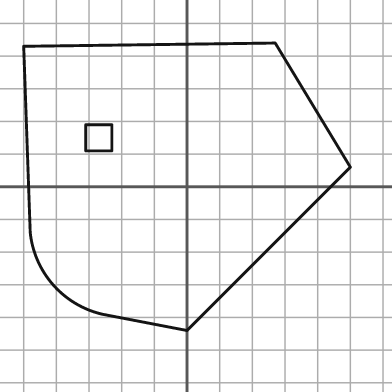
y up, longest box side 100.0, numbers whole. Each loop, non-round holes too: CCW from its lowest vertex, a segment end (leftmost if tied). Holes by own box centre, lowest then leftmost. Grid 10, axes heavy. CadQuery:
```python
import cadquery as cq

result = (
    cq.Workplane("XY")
    .moveTo(0.0, -44.0)
    .lineTo(50.0, 6.0)
    .lineTo(27.0, 44.0)
    .lineTo(-50.0, 43.0)
    .lineTo(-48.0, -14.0)
    .threePointArc((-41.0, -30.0), (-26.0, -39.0))
    .close()
    .moveTo(-31.0, 11.0)
    .lineTo(-23.0, 11.0)
    .lineTo(-23.0, 19.0)
    .lineTo(-31.0, 19.0)
    .close()
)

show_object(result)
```